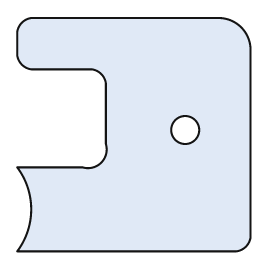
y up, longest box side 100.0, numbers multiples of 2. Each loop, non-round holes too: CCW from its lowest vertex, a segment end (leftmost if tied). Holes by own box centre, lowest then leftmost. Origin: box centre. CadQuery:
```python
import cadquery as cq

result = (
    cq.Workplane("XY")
    .moveTo(-50.0, -50.0)
    .lineTo(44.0, -50.0)
    .threePointArc((48.0, -48.0), (50.0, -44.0))
    .lineTo(50.0, 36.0)
    .threePointArc((46.0, 46.0), (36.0, 50.0))
    .lineTo(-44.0, 50.0)
    .threePointArc((-48.0, 48.0), (-50.0, 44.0))
    .lineTo(-50.0, 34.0)
    .threePointArc((-48.0, 30.0), (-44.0, 28.0))
    .lineTo(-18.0, 28.0)
    .threePointArc((-14.0, 26.0), (-12.0, 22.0))
    .lineTo(-12.0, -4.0)
    .threePointArc((-14.0, -12.0), (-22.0, -14.0))
    .lineTo(-50.0, -14.0)
    .threePointArc((-44.0, -32.0), (-50.0, -50.0))
    .close()
    .moveTo(22.0, 2.0)
    .circle(6.0)
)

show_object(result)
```